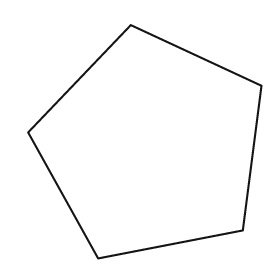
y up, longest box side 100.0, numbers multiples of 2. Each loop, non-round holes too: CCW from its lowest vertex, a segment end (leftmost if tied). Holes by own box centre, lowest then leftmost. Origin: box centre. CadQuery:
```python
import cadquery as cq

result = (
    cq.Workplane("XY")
    .moveTo(-20.0, -50.0)
    .lineTo(42.0, -38.0)
    .lineTo(50.0, 24.0)
    .lineTo(-6.0, 50.0)
    .lineTo(-50.0, 4.0)
    .close()
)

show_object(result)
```